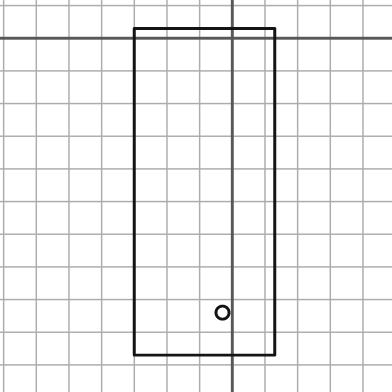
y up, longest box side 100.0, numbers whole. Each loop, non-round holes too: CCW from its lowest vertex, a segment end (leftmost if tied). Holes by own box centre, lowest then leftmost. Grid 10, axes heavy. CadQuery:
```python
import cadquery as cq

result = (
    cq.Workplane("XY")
    .moveTo(-30.0, -97.0)
    .lineTo(13.0, -97.0)
    .lineTo(13.0, 3.0)
    .lineTo(-30.0, 3.0)
    .close()
    .moveTo(-3.0, -84.0)
    .circle(2.0)
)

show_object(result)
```